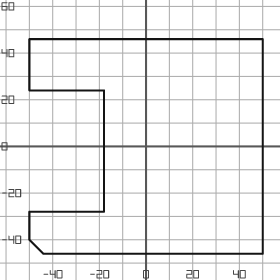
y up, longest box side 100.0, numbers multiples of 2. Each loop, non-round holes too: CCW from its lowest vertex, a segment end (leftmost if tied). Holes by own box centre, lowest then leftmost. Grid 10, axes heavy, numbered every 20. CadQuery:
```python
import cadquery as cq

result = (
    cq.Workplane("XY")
    .moveTo(-44.0, -46.0)
    .lineTo(50.0, -46.0)
    .lineTo(50.0, 46.0)
    .lineTo(-50.0, 46.0)
    .lineTo(-50.0, 24.0)
    .lineTo(-18.0, 24.0)
    .lineTo(-18.0, -28.0)
    .lineTo(-50.0, -28.0)
    .lineTo(-50.0, -40.0)
    .close()
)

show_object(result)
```